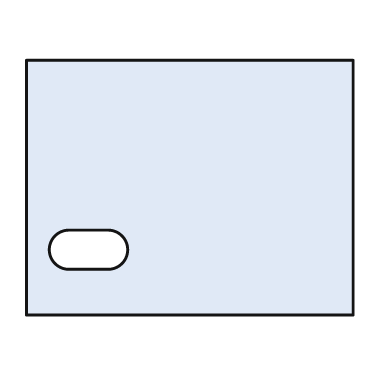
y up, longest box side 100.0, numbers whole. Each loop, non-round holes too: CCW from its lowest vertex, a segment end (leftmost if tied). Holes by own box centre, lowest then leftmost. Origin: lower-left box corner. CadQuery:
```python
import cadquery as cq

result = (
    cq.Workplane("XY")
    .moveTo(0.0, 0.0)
    .lineTo(100.0, 0.0)
    .lineTo(100.0, 78.0)
    .lineTo(0.0, 78.0)
    .close()
    .moveTo(13.0, 14.0)
    .lineTo(25.0, 14.0)
    .threePointArc((31.0, 20.0), (25.0, 26.0))
    .lineTo(13.0, 26.0)
    .threePointArc((7.0, 20.0), (13.0, 14.0))
    .close()
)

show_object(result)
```